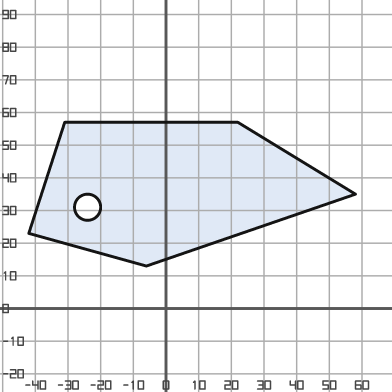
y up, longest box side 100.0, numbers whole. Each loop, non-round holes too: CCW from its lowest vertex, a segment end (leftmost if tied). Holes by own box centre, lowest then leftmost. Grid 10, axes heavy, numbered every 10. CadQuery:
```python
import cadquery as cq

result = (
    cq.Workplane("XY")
    .moveTo(-6.0, 13.0)
    .lineTo(58.0, 35.0)
    .lineTo(22.0, 57.0)
    .lineTo(-31.0, 57.0)
    .lineTo(-42.0, 23.0)
    .close()
    .moveTo(-24.0, 31.0)
    .circle(4.0)
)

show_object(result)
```